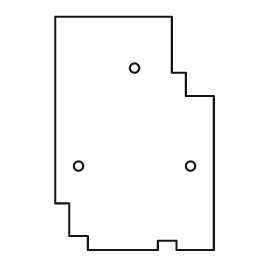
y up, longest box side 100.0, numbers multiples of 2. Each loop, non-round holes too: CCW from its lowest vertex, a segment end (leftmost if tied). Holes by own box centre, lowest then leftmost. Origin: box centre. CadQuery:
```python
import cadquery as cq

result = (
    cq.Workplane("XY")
    .moveTo(-20.0, -50.0)
    .lineTo(10.0, -50.0)
    .lineTo(10.0, -46.0)
    .lineTo(18.0, -46.0)
    .lineTo(18.0, -50.0)
    .lineTo(34.0, -50.0)
    .lineTo(34.0, 16.0)
    .lineTo(22.0, 16.0)
    .lineTo(22.0, 26.0)
    .lineTo(16.0, 26.0)
    .lineTo(16.0, 50.0)
    .lineTo(-34.0, 50.0)
    .lineTo(-34.0, -30.0)
    .lineTo(-28.0, -30.0)
    .lineTo(-28.0, -44.0)
    .lineTo(-20.0, -44.0)
    .close()
    .moveTo(-24.0, -14.0)
    .circle(2.0)
    .moveTo(24.0, -14.0)
    .circle(2.0)
    .moveTo(0.0, 28.0)
    .circle(2.0)
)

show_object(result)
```